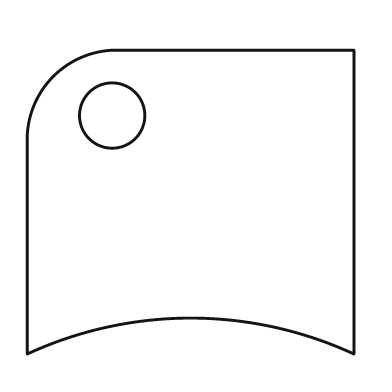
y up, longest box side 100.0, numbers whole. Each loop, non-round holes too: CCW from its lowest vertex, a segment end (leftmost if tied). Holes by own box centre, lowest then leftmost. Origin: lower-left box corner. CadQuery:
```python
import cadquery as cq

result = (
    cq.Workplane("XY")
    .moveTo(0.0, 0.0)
    .threePointArc((50.0, 11.0), (100.0, 0.0))
    .lineTo(100.0, 93.0)
    .lineTo(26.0, 93.0)
    .threePointArc((8.0, 85.0), (0.0, 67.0))
    .close()
    .moveTo(26.0, 73.0)
    .circle(10.0)
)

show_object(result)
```